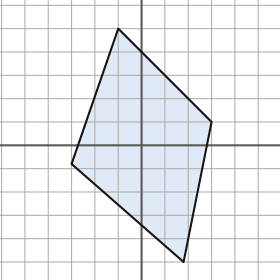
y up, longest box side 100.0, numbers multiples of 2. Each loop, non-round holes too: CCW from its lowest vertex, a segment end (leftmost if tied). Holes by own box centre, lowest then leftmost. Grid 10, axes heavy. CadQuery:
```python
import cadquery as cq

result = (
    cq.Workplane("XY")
    .moveTo(18.0, -50.0)
    .lineTo(30.0, 10.0)
    .lineTo(-10.0, 50.0)
    .lineTo(-30.0, -8.0)
    .close()
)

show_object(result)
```